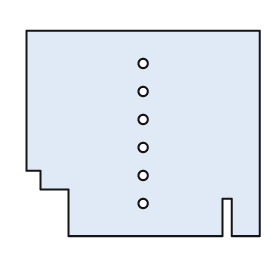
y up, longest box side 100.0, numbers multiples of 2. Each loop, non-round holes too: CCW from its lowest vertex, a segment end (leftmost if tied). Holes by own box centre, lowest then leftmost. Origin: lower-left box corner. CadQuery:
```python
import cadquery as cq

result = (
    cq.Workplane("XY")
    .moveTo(18.0, 0.0)
    .lineTo(84.0, 0.0)
    .lineTo(84.0, 16.0)
    .lineTo(88.0, 16.0)
    .lineTo(88.0, 0.0)
    .lineTo(100.0, 0.0)
    .lineTo(100.0, 88.0)
    .lineTo(0.0, 88.0)
    .lineTo(0.0, 28.0)
    .lineTo(6.0, 28.0)
    .lineTo(6.0, 20.0)
    .lineTo(18.0, 20.0)
    .close()
    .moveTo(50.0, 14.0)
    .circle(2.0)
    .moveTo(50.0, 26.0)
    .circle(2.0)
    .moveTo(50.0, 38.0)
    .circle(2.0)
    .moveTo(50.0, 50.0)
    .circle(2.0)
    .moveTo(50.0, 62.0)
    .circle(2.0)
    .moveTo(50.0, 74.0)
    .circle(2.0)
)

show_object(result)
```